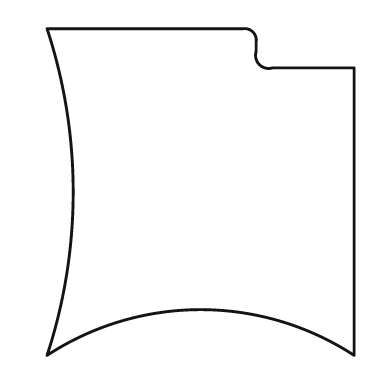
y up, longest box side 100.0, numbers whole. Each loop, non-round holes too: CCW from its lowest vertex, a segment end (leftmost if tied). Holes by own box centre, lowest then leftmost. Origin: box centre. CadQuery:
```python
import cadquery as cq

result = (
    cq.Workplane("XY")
    .moveTo(-47.0, -50.0)
    .threePointArc((0.0, -36.0), (47.0, -50.0))
    .lineTo(47.0, 38.0)
    .lineTo(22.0, 38.0)
    .threePointArc((18.0, 39.0), (17.0, 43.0))
    .lineTo(17.0, 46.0)
    .threePointArc((16.0, 49.0), (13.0, 50.0))
    .lineTo(-47.0, 50.0)
    .threePointArc((-39.0, 0.0), (-47.0, -50.0))
    .close()
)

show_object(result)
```